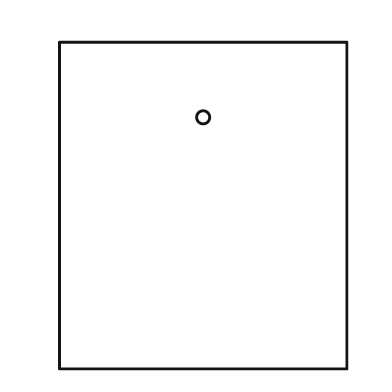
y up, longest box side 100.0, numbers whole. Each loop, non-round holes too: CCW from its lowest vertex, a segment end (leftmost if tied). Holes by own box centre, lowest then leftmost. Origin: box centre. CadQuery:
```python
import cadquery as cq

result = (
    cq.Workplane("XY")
    .moveTo(-44.0, -50.0)
    .lineTo(44.0, -50.0)
    .lineTo(44.0, 50.0)
    .lineTo(-44.0, 50.0)
    .close()
    .moveTo(0.0, 27.0)
    .circle(2.0)
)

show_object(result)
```